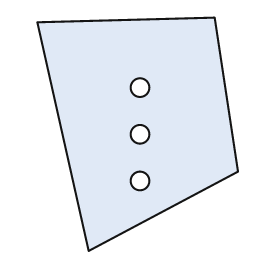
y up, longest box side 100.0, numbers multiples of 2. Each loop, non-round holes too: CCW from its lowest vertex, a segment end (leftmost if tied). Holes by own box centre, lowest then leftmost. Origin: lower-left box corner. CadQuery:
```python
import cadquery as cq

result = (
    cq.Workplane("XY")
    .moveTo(22.0, 0.0)
    .lineTo(86.0, 34.0)
    .lineTo(76.0, 100.0)
    .lineTo(0.0, 98.0)
    .close()
    .moveTo(44.0, 30.0)
    .circle(4.0)
    .moveTo(44.0, 50.0)
    .circle(4.0)
    .moveTo(44.0, 70.0)
    .circle(4.0)
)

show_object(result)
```